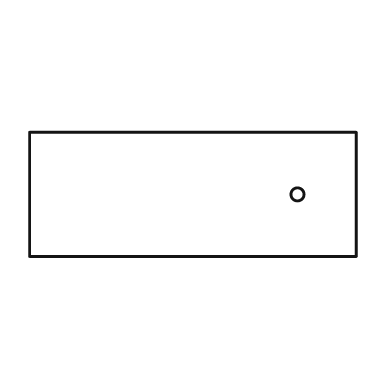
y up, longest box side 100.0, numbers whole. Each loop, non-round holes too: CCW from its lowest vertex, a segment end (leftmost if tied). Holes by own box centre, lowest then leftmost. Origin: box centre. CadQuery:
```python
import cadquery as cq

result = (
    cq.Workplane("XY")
    .moveTo(-50.0, -19.0)
    .lineTo(50.0, -19.0)
    .lineTo(50.0, 19.0)
    .lineTo(-50.0, 19.0)
    .close()
    .moveTo(32.0, 0.0)
    .circle(2.0)
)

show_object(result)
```